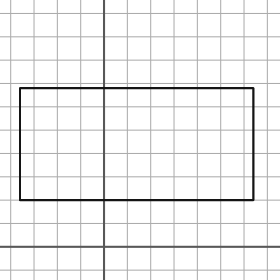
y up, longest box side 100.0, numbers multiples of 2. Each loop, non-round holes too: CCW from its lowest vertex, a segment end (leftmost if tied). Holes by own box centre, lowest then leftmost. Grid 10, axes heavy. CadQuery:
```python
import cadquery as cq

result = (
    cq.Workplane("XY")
    .moveTo(-36.0, 20.0)
    .lineTo(64.0, 20.0)
    .lineTo(64.0, 68.0)
    .lineTo(-36.0, 68.0)
    .close()
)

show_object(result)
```